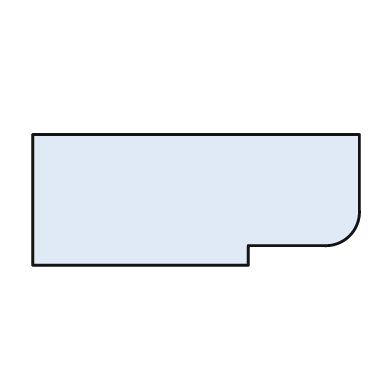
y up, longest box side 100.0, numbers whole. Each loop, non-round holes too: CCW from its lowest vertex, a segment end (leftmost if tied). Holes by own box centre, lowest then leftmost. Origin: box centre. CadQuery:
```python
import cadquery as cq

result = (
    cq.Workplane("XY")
    .moveTo(-50.0, -20.0)
    .lineTo(16.0, -20.0)
    .lineTo(16.0, -14.0)
    .lineTo(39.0, -14.0)
    .threePointArc((47.0, -11.0), (50.0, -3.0))
    .lineTo(50.0, 20.0)
    .lineTo(-50.0, 20.0)
    .close()
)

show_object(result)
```